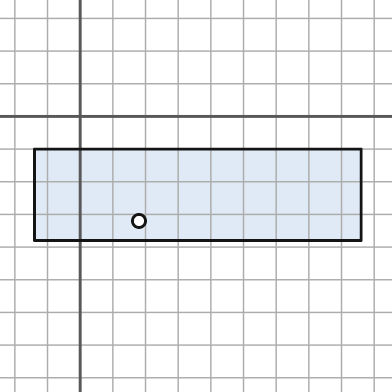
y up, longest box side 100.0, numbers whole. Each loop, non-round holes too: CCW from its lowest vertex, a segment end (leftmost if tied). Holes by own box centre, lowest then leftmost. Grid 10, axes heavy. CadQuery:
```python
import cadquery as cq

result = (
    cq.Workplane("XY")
    .moveTo(-14.0, -38.0)
    .lineTo(86.0, -38.0)
    .lineTo(86.0, -10.0)
    .lineTo(-14.0, -10.0)
    .close()
    .moveTo(18.0, -32.0)
    .circle(2.0)
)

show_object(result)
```